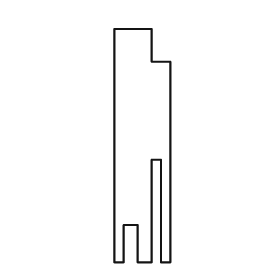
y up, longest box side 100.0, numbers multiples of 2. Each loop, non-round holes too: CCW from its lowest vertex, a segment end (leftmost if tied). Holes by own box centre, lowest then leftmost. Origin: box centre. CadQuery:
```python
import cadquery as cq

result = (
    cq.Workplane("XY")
    .moveTo(-12.0, -50.0)
    .lineTo(-8.0, -50.0)
    .lineTo(-8.0, -34.0)
    .lineTo(-2.0, -34.0)
    .lineTo(-2.0, -50.0)
    .lineTo(4.0, -50.0)
    .lineTo(4.0, -6.0)
    .lineTo(8.0, -6.0)
    .lineTo(8.0, -50.0)
    .lineTo(12.0, -50.0)
    .lineTo(12.0, 36.0)
    .lineTo(4.0, 36.0)
    .lineTo(4.0, 50.0)
    .lineTo(-12.0, 50.0)
    .close()
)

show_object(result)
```